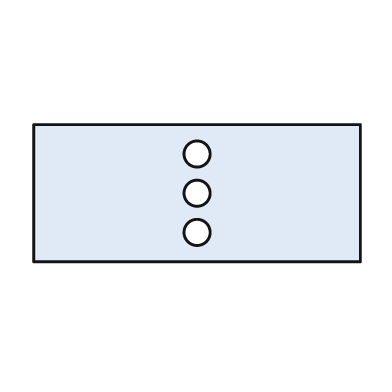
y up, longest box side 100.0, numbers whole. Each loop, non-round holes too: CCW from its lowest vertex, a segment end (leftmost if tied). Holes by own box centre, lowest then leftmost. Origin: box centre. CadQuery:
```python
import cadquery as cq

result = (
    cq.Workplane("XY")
    .moveTo(-50.0, -21.0)
    .lineTo(50.0, -21.0)
    .lineTo(50.0, 21.0)
    .lineTo(-50.0, 21.0)
    .close()
    .moveTo(0.0, -12.0)
    .circle(4.0)
    .moveTo(0.0, 0.0)
    .circle(4.0)
    .moveTo(0.0, 12.0)
    .circle(4.0)
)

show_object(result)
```